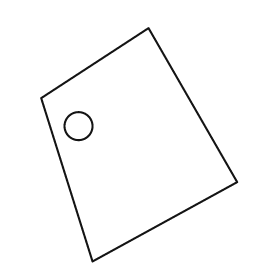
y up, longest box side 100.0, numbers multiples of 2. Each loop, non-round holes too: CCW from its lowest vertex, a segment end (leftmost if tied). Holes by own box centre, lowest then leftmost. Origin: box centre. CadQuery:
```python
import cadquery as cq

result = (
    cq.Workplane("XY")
    .moveTo(-20.0, -50.0)
    .lineTo(42.0, -16.0)
    .lineTo(4.0, 50.0)
    .lineTo(-42.0, 20.0)
    .close()
    .moveTo(-26.0, 8.0)
    .circle(6.0)
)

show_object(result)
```